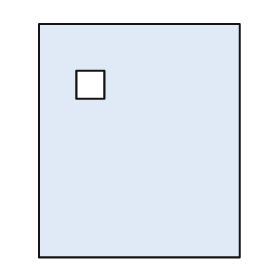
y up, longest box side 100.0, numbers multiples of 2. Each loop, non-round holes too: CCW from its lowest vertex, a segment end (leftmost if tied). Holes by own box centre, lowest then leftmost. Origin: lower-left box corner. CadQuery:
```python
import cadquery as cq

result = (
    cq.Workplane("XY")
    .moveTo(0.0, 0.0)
    .lineTo(86.0, 0.0)
    .lineTo(86.0, 100.0)
    .lineTo(0.0, 100.0)
    .close()
    .moveTo(16.0, 68.0)
    .lineTo(28.0, 68.0)
    .lineTo(28.0, 80.0)
    .lineTo(16.0, 80.0)
    .close()
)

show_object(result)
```